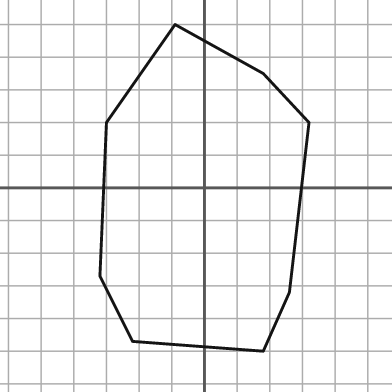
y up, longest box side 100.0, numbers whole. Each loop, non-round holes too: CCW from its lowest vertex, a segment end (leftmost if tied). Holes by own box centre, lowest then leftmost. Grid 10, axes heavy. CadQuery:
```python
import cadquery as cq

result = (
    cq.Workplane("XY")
    .moveTo(18.0, -50.0)
    .lineTo(26.0, -32.0)
    .lineTo(32.0, 20.0)
    .lineTo(18.0, 35.0)
    .lineTo(-9.0, 50.0)
    .lineTo(-30.0, 20.0)
    .lineTo(-32.0, -27.0)
    .lineTo(-22.0, -47.0)
    .close()
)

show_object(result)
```